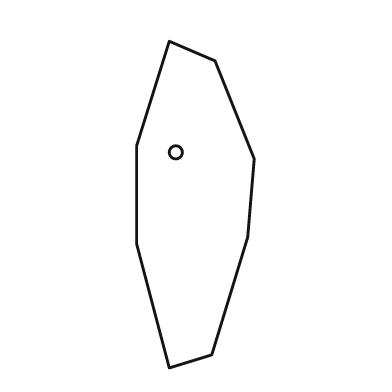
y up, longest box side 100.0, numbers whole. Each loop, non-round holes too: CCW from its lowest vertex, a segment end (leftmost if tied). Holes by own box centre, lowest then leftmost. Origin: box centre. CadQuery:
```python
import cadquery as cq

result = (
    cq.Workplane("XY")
    .moveTo(-8.0, -50.0)
    .lineTo(5.0, -46.0)
    .lineTo(16.0, -10.0)
    .lineTo(18.0, 14.0)
    .lineTo(6.0, 44.0)
    .lineTo(-8.0, 50.0)
    .lineTo(-18.0, 18.0)
    .lineTo(-18.0, -12.0)
    .close()
    .moveTo(-6.0, 16.0)
    .circle(2.0)
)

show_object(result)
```